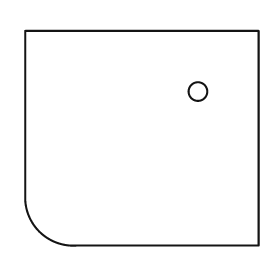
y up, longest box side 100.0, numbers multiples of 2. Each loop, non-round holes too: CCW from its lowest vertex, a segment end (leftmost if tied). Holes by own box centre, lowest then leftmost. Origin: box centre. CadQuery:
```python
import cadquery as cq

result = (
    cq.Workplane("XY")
    .moveTo(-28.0, -46.0)
    .lineTo(50.0, -46.0)
    .lineTo(50.0, 46.0)
    .lineTo(-50.0, 46.0)
    .lineTo(-50.0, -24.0)
    .threePointArc((-44.0, -40.0), (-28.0, -46.0))
    .close()
    .moveTo(24.0, 20.0)
    .circle(4.0)
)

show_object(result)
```